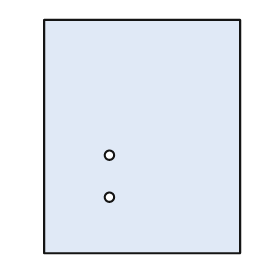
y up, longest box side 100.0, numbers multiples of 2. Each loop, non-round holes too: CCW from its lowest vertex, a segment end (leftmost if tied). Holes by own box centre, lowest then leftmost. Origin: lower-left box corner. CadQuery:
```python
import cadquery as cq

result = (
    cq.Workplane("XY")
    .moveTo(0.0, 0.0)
    .lineTo(84.0, 0.0)
    .lineTo(84.0, 100.0)
    .lineTo(0.0, 100.0)
    .close()
    .moveTo(28.0, 24.0)
    .circle(2.0)
    .moveTo(28.0, 42.0)
    .circle(2.0)
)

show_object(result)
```